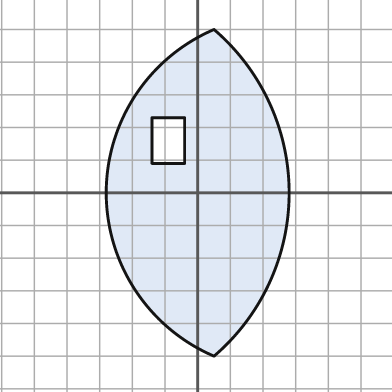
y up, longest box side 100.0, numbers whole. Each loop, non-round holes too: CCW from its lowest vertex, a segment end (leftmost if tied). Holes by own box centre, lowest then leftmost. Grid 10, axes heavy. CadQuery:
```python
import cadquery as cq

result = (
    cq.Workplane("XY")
    .moveTo(5.0, -50.0)
    .threePointArc((28.0, 0.0), (5.0, 50.0))
    .threePointArc((-28.0, 0.0), (5.0, -50.0))
    .close()
    .moveTo(-14.0, 9.0)
    .lineTo(-4.0, 9.0)
    .lineTo(-4.0, 23.0)
    .lineTo(-14.0, 23.0)
    .close()
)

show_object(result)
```